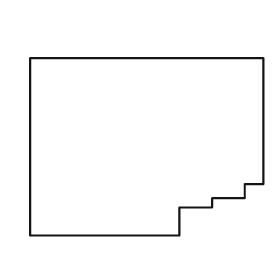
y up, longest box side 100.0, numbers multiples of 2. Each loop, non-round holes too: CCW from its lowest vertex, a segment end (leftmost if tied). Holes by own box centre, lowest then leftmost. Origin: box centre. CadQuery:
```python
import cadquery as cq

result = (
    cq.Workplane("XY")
    .moveTo(-50.0, -38.0)
    .lineTo(14.0, -38.0)
    .lineTo(14.0, -26.0)
    .lineTo(28.0, -26.0)
    .lineTo(28.0, -22.0)
    .lineTo(42.0, -22.0)
    .lineTo(42.0, -16.0)
    .lineTo(50.0, -16.0)
    .lineTo(50.0, 38.0)
    .lineTo(-50.0, 38.0)
    .close()
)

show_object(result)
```